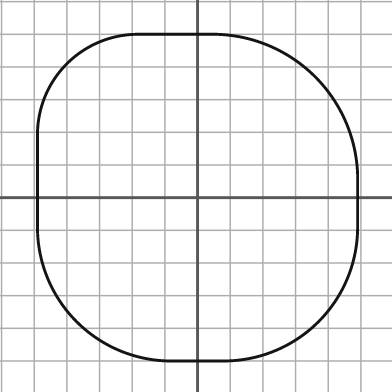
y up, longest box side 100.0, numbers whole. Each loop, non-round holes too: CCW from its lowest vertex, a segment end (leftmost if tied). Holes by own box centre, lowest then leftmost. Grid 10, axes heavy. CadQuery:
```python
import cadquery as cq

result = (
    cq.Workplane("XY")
    .moveTo(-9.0, -50.0)
    .lineTo(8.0, -50.0)
    .threePointArc((37.0, -38.0), (49.0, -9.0))
    .lineTo(49.0, 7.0)
    .threePointArc((36.0, 37.0), (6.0, 50.0))
    .lineTo(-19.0, 50.0)
    .threePointArc((-40.0, 41.0), (-49.0, 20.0))
    .lineTo(-49.0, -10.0)
    .threePointArc((-37.0, -38.0), (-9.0, -50.0))
    .close()
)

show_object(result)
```